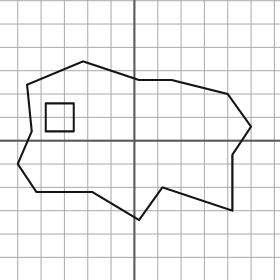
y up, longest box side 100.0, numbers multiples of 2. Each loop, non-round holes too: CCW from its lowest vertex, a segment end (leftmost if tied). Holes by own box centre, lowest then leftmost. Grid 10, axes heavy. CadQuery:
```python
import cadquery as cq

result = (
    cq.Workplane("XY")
    .moveTo(2.0, -34.0)
    .lineTo(12.0, -20.0)
    .lineTo(42.0, -30.0)
    .lineTo(42.0, -6.0)
    .lineTo(50.0, 6.0)
    .lineTo(40.0, 20.0)
    .lineTo(16.0, 26.0)
    .lineTo(2.0, 26.0)
    .lineTo(-22.0, 34.0)
    .lineTo(-46.0, 24.0)
    .lineTo(-44.0, 4.0)
    .lineTo(-50.0, -10.0)
    .lineTo(-42.0, -22.0)
    .lineTo(-18.0, -22.0)
    .close()
    .moveTo(-38.0, 4.0)
    .lineTo(-26.0, 4.0)
    .lineTo(-26.0, 16.0)
    .lineTo(-38.0, 16.0)
    .close()
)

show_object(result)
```